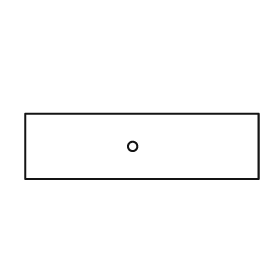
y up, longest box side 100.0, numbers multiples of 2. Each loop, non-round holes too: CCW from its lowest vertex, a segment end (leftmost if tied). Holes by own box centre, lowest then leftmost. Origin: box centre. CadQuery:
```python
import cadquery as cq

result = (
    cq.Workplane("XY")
    .moveTo(-50.0, -14.0)
    .lineTo(50.0, -14.0)
    .lineTo(50.0, 14.0)
    .lineTo(-50.0, 14.0)
    .close()
    .moveTo(-4.0, 0.0)
    .circle(2.0)
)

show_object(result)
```